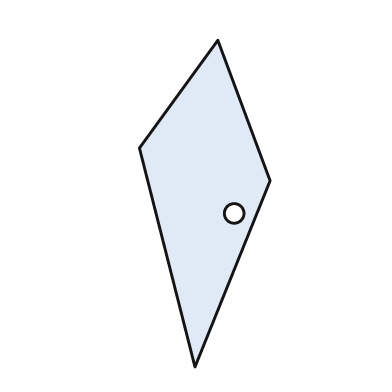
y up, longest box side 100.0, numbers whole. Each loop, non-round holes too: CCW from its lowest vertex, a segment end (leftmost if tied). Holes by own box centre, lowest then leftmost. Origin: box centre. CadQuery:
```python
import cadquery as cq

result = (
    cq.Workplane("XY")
    .moveTo(-3.0, -50.0)
    .lineTo(20.0, 7.0)
    .lineTo(4.0, 50.0)
    .lineTo(-20.0, 17.0)
    .close()
    .moveTo(9.0, -3.0)
    .circle(3.0)
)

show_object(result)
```